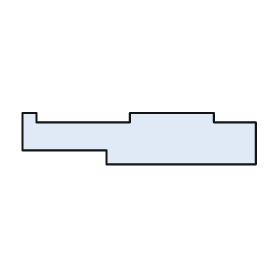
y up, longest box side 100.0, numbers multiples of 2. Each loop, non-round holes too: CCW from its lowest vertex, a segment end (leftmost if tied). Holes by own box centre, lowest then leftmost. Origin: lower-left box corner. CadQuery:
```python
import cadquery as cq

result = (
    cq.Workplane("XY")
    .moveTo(36.0, 0.0)
    .lineTo(100.0, 0.0)
    .lineTo(100.0, 18.0)
    .lineTo(82.0, 18.0)
    .lineTo(82.0, 22.0)
    .lineTo(46.0, 22.0)
    .lineTo(46.0, 18.0)
    .lineTo(6.0, 18.0)
    .lineTo(6.0, 22.0)
    .lineTo(0.0, 22.0)
    .lineTo(0.0, 6.0)
    .lineTo(36.0, 6.0)
    .close()
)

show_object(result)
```